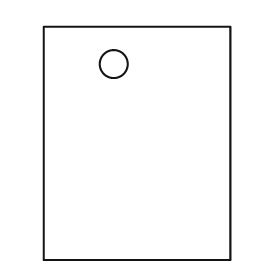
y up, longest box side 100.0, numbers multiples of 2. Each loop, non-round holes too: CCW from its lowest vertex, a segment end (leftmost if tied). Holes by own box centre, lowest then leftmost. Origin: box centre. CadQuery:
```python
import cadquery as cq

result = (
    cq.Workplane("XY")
    .moveTo(-40.0, -50.0)
    .lineTo(40.0, -50.0)
    .lineTo(40.0, 50.0)
    .lineTo(-40.0, 50.0)
    .close()
    .moveTo(-10.0, 34.0)
    .circle(6.0)
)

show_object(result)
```